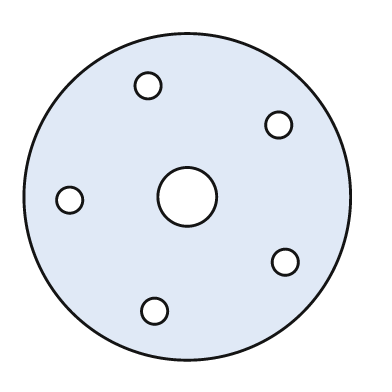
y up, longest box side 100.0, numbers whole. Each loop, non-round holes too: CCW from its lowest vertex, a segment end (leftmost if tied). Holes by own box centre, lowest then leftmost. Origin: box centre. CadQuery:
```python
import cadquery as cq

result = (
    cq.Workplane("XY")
    .moveTo(0.0, 0.0)
    .circle(50.0)
    .moveTo(-10.0, -35.0)
    .circle(4.0)
    .moveTo(30.0, -20.0)
    .circle(4.0)
    .moveTo(-36.0, -1.0)
    .circle(4.0)
    .moveTo(0.0, 0.0)
    .circle(9.0)
    .moveTo(28.0, 22.0)
    .circle(4.0)
    .moveTo(-12.0, 34.0)
    .circle(4.0)
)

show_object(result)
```